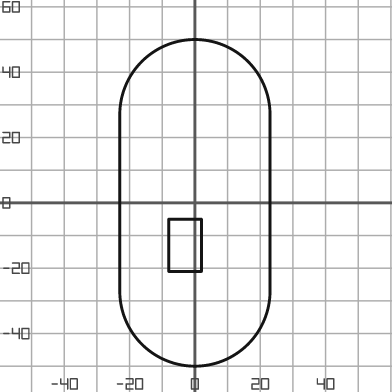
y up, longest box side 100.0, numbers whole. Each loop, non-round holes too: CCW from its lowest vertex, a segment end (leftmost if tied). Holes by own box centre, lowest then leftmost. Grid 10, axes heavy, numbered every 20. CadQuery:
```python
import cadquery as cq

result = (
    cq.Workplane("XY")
    .moveTo(-23.0, -27.0)
    .threePointArc((0.0, -50.0), (23.0, -27.0))
    .lineTo(23.0, 27.0)
    .threePointArc((0.0, 50.0), (-23.0, 27.0))
    .close()
    .moveTo(-8.0, -21.0)
    .lineTo(2.0, -21.0)
    .lineTo(2.0, -5.0)
    .lineTo(-8.0, -5.0)
    .close()
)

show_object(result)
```